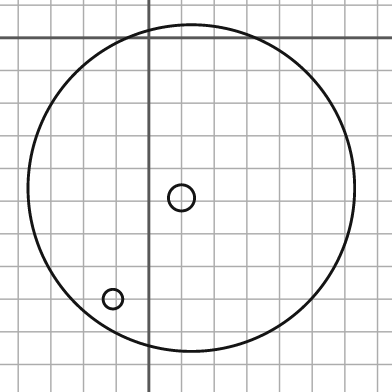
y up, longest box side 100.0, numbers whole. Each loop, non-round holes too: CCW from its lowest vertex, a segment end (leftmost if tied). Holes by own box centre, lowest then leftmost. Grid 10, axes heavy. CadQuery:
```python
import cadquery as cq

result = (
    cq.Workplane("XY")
    .moveTo(13.0, -46.0)
    .circle(50.0)
    .moveTo(-11.0, -80.0)
    .circle(3.0)
    .moveTo(10.0, -49.0)
    .circle(4.0)
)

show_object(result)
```